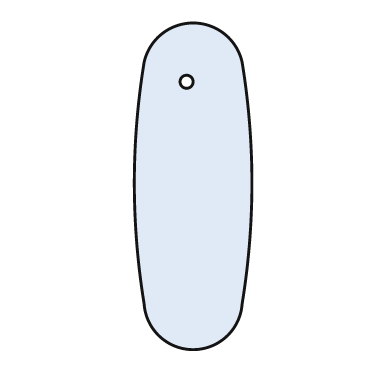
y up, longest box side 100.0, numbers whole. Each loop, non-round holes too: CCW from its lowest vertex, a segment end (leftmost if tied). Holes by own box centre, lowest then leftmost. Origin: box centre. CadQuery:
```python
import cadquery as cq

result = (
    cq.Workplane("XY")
    .moveTo(-15.0, -36.0)
    .threePointArc((0.0, -50.0), (15.0, -36.0))
    .threePointArc((18.0, 1.0), (15.0, 38.0))
    .threePointArc((0.0, 50.0), (-15.0, 38.0))
    .threePointArc((-18.0, 1.0), (-15.0, -36.0))
    .close()
    .moveTo(-2.0, 32.0)
    .circle(2.0)
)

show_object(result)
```